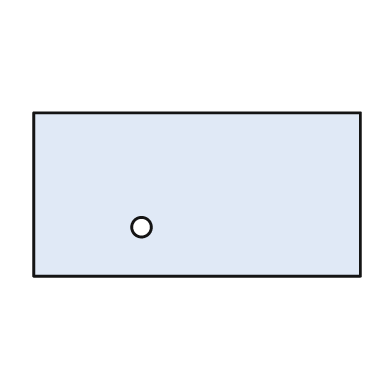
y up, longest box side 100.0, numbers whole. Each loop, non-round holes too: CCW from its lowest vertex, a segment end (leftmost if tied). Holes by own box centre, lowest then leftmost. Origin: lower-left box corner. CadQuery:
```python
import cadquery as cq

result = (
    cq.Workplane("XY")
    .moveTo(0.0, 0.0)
    .lineTo(100.0, 0.0)
    .lineTo(100.0, 50.0)
    .lineTo(0.0, 50.0)
    .close()
    .moveTo(33.0, 15.0)
    .circle(3.0)
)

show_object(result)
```